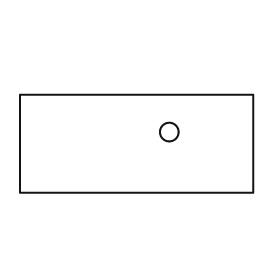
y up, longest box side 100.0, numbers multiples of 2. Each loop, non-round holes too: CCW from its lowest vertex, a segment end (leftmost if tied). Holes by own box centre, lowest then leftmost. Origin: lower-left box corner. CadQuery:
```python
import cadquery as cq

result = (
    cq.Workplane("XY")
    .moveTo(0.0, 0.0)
    .lineTo(100.0, 0.0)
    .lineTo(100.0, 42.0)
    .lineTo(0.0, 42.0)
    .close()
    .moveTo(64.0, 26.0)
    .circle(4.0)
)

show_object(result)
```